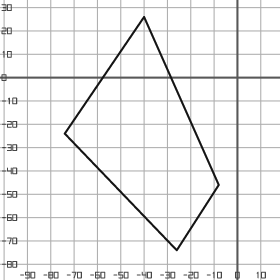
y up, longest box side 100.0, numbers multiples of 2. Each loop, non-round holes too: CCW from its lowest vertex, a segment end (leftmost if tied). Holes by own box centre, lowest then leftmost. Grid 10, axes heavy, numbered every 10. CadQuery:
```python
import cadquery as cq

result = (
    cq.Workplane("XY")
    .moveTo(-26.0, -74.0)
    .lineTo(-8.0, -46.0)
    .lineTo(-40.0, 26.0)
    .lineTo(-74.0, -24.0)
    .close()
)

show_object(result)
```